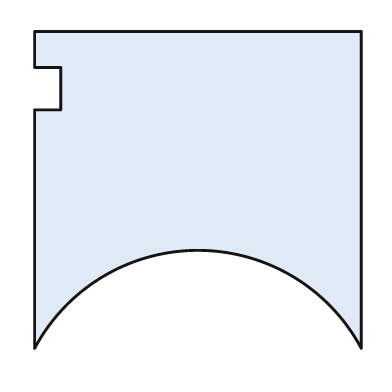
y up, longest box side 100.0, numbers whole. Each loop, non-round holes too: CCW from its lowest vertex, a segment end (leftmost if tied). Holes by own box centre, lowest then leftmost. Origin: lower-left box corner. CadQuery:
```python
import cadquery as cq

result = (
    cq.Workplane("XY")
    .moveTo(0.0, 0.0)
    .threePointArc((50.0, 30.0), (100.0, 0.0))
    .lineTo(100.0, 97.0)
    .lineTo(0.0, 97.0)
    .lineTo(0.0, 86.0)
    .lineTo(8.0, 86.0)
    .lineTo(8.0, 73.0)
    .lineTo(0.0, 73.0)
    .close()
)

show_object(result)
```